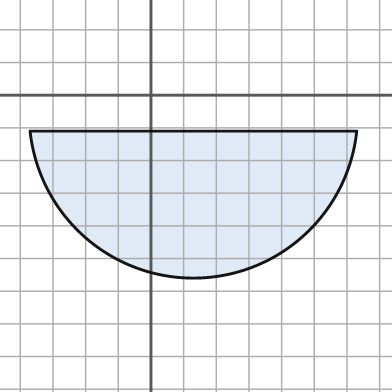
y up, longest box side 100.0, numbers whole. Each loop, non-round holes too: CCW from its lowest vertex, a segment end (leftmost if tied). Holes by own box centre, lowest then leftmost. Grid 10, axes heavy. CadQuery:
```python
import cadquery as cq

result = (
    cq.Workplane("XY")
    .moveTo(-37.0, -11.0)
    .threePointArc((13.0, -56.0), (63.0, -11.0))
    .close()
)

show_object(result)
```